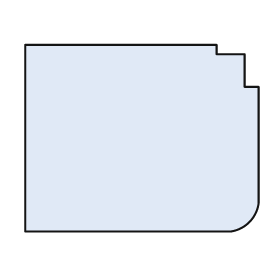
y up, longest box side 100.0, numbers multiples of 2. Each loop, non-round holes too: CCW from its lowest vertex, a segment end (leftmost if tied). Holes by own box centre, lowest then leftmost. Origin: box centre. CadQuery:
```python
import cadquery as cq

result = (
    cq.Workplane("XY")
    .moveTo(-50.0, -40.0)
    .lineTo(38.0, -40.0)
    .threePointArc((46.0, -36.0), (50.0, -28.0))
    .lineTo(50.0, 22.0)
    .lineTo(44.0, 22.0)
    .lineTo(44.0, 36.0)
    .lineTo(32.0, 36.0)
    .lineTo(32.0, 40.0)
    .lineTo(-50.0, 40.0)
    .close()
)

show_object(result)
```